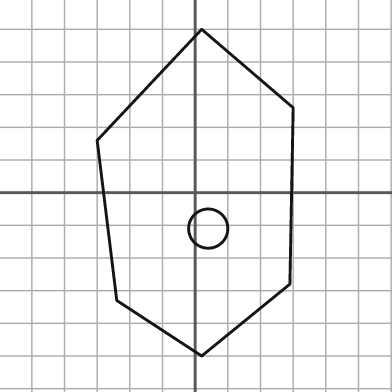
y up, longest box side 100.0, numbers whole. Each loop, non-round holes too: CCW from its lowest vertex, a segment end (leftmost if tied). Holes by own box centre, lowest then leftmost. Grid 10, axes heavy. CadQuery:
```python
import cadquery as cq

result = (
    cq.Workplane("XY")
    .moveTo(2.0, -50.0)
    .lineTo(29.0, -28.0)
    .lineTo(30.0, 26.0)
    .lineTo(2.0, 50.0)
    .lineTo(-30.0, 16.0)
    .lineTo(-24.0, -33.0)
    .close()
    .moveTo(4.0, -11.0)
    .circle(6.0)
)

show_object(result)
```